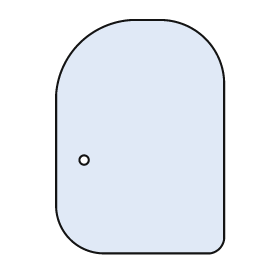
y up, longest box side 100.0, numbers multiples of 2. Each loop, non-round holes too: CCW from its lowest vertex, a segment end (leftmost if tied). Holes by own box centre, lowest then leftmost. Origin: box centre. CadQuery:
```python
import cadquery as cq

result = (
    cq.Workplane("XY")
    .moveTo(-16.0, -50.0)
    .lineTo(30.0, -50.0)
    .threePointArc((34.0, -48.0), (36.0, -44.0))
    .lineTo(36.0, 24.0)
    .threePointArc((28.0, 42.0), (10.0, 50.0))
    .lineTo(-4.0, 50.0)
    .threePointArc((-26.0, 40.0), (-36.0, 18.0))
    .lineTo(-36.0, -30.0)
    .threePointArc((-30.0, -44.0), (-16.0, -50.0))
    .close()
    .moveTo(-24.0, -10.0)
    .circle(2.0)
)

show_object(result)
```